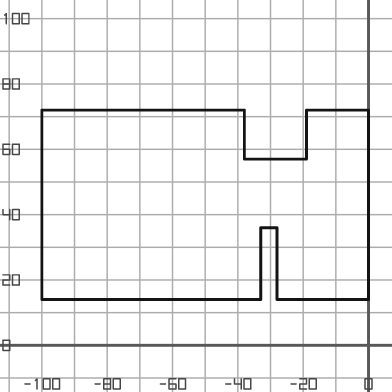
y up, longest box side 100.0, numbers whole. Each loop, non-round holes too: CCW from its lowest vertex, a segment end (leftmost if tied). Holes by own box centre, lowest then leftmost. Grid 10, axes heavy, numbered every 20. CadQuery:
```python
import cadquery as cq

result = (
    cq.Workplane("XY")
    .moveTo(-100.0, 14.0)
    .lineTo(-33.0, 14.0)
    .lineTo(-33.0, 36.0)
    .lineTo(-28.0, 36.0)
    .lineTo(-28.0, 14.0)
    .lineTo(0.0, 14.0)
    .lineTo(0.0, 72.0)
    .lineTo(-19.0, 72.0)
    .lineTo(-19.0, 57.0)
    .lineTo(-38.0, 57.0)
    .lineTo(-38.0, 72.0)
    .lineTo(-100.0, 72.0)
    .close()
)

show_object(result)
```